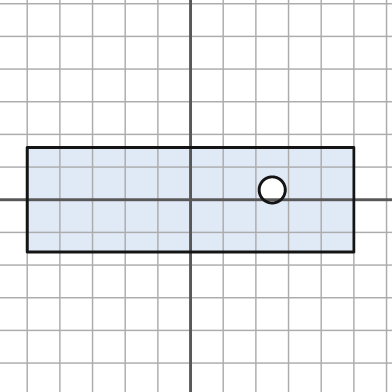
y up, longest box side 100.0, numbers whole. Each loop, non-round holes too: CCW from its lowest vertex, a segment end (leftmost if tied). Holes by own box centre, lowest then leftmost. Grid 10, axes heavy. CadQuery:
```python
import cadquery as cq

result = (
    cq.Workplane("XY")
    .moveTo(-50.0, -16.0)
    .lineTo(50.0, -16.0)
    .lineTo(50.0, 16.0)
    .lineTo(-50.0, 16.0)
    .close()
    .moveTo(25.0, 3.0)
    .circle(4.0)
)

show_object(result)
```